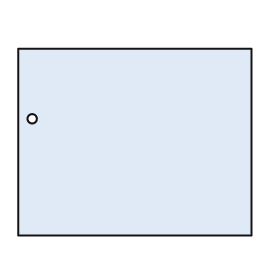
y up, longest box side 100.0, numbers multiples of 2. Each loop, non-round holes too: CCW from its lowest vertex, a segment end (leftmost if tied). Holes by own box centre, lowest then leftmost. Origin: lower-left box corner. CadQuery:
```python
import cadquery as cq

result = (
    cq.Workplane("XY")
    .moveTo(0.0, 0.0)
    .lineTo(100.0, 0.0)
    .lineTo(100.0, 80.0)
    .lineTo(0.0, 80.0)
    .close()
    .moveTo(6.0, 50.0)
    .circle(2.0)
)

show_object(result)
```